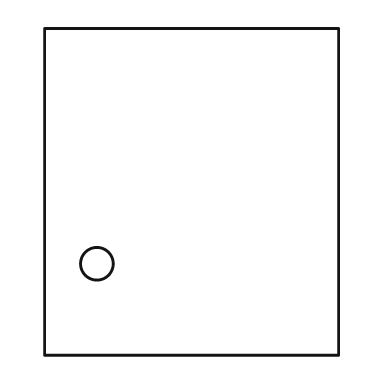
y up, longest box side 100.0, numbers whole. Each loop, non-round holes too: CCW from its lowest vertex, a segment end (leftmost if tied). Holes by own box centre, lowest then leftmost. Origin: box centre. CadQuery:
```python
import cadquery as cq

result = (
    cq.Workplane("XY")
    .moveTo(-45.0, -50.0)
    .lineTo(45.0, -50.0)
    .lineTo(45.0, 50.0)
    .lineTo(-45.0, 50.0)
    .close()
    .moveTo(-29.0, -22.0)
    .circle(5.0)
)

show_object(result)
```